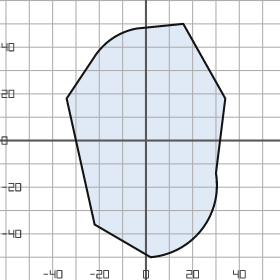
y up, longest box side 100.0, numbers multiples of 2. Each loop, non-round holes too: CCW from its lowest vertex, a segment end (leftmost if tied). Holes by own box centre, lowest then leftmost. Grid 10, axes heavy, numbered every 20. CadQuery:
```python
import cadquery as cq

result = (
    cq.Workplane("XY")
    .moveTo(2.0, -50.0)
    .threePointArc((24.0, -38.0), (30.0, -14.0))
    .lineTo(34.0, 18.0)
    .lineTo(16.0, 50.0)
    .lineTo(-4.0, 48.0)
    .threePointArc((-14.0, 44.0), (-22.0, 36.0))
    .lineTo(-34.0, 18.0)
    .lineTo(-22.0, -36.0)
    .close()
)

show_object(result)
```